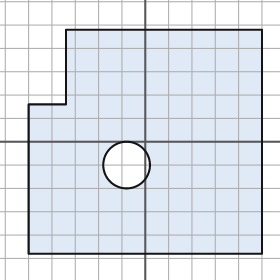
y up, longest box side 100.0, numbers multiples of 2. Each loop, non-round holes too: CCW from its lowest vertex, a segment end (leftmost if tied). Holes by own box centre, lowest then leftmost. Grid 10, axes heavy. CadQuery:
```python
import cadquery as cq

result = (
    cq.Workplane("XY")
    .moveTo(-50.0, -48.0)
    .lineTo(50.0, -48.0)
    .lineTo(50.0, 48.0)
    .lineTo(-34.0, 48.0)
    .lineTo(-34.0, 16.0)
    .lineTo(-50.0, 16.0)
    .close()
    .moveTo(-8.0, -10.0)
    .circle(10.0)
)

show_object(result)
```